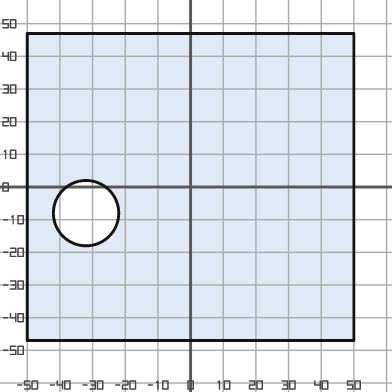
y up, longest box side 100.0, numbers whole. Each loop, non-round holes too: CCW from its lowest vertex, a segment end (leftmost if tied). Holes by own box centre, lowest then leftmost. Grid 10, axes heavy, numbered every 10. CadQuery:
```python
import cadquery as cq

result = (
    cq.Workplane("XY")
    .moveTo(-50.0, -47.0)
    .lineTo(50.0, -47.0)
    .lineTo(50.0, 47.0)
    .lineTo(-50.0, 47.0)
    .close()
    .moveTo(-32.0, -8.0)
    .circle(10.0)
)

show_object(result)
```